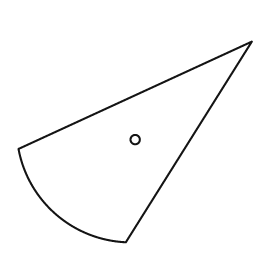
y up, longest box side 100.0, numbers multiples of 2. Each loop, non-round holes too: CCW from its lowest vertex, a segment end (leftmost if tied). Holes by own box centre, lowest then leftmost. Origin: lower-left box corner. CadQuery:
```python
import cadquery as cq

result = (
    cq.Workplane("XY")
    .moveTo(46.0, 0.0)
    .lineTo(100.0, 86.0)
    .lineTo(0.0, 40.0)
    .threePointArc((16.0, 12.0), (46.0, 0.0))
    .close()
    .moveTo(50.0, 44.0)
    .circle(2.0)
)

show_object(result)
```